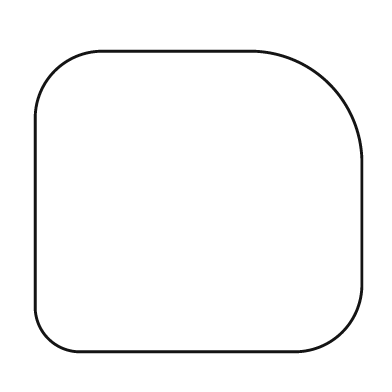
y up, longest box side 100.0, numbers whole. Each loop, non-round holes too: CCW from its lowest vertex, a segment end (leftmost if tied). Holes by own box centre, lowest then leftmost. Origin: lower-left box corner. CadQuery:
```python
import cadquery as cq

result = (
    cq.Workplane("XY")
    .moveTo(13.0, 0.0)
    .lineTo(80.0, 0.0)
    .threePointArc((94.0, 6.0), (100.0, 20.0))
    .lineTo(100.0, 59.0)
    .threePointArc((90.0, 82.0), (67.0, 92.0))
    .lineTo(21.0, 92.0)
    .threePointArc((6.0, 86.0), (0.0, 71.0))
    .lineTo(0.0, 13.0)
    .threePointArc((4.0, 4.0), (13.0, 0.0))
    .close()
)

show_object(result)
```